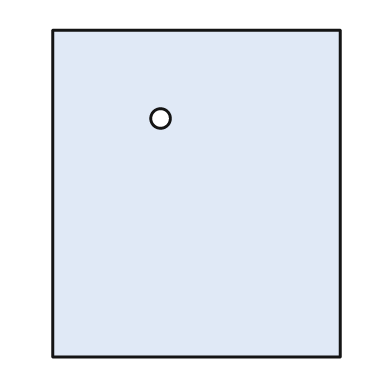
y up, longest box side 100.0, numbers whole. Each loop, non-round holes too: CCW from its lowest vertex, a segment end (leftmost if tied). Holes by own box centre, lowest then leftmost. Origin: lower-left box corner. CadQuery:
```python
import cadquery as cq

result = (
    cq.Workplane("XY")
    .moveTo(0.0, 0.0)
    .lineTo(88.0, 0.0)
    .lineTo(88.0, 100.0)
    .lineTo(0.0, 100.0)
    .close()
    .moveTo(33.0, 73.0)
    .circle(3.0)
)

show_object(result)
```